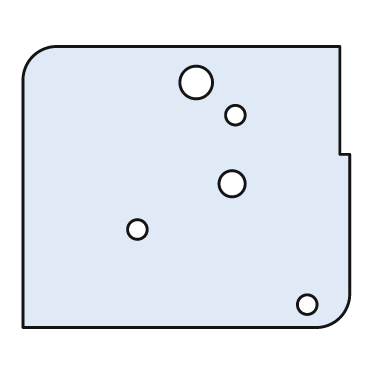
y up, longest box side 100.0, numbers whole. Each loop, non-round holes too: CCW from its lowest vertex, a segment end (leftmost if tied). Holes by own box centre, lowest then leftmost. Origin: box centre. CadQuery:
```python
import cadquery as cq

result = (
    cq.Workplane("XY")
    .moveTo(-50.0, -43.0)
    .lineTo(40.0, -43.0)
    .threePointArc((47.0, -40.0), (50.0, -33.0))
    .lineTo(50.0, 10.0)
    .lineTo(47.0, 10.0)
    .lineTo(47.0, 43.0)
    .lineTo(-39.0, 43.0)
    .threePointArc((-47.0, 40.0), (-50.0, 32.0))
    .close()
    .moveTo(37.0, -36.0)
    .circle(3.0)
    .moveTo(-15.0, -13.0)
    .circle(3.0)
    .moveTo(14.0, 1.0)
    .circle(4.0)
    .moveTo(15.0, 22.0)
    .circle(3.0)
    .moveTo(3.0, 32.0)
    .circle(5.0)
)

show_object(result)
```